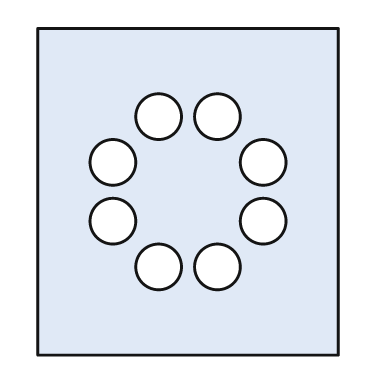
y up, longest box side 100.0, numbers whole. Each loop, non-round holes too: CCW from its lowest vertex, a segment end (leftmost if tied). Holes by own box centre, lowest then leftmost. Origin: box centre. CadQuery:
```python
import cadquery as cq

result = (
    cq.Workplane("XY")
    .moveTo(-46.0, -50.0)
    .lineTo(46.0, -50.0)
    .lineTo(46.0, 50.0)
    .lineTo(-46.0, 50.0)
    .close()
    .moveTo(-9.0, -23.0)
    .circle(7.0)
    .moveTo(9.0, -23.0)
    .circle(7.0)
    .moveTo(-23.0, -9.0)
    .circle(7.0)
    .moveTo(23.0, -9.0)
    .circle(7.0)
    .moveTo(-23.0, 9.0)
    .circle(7.0)
    .moveTo(23.0, 9.0)
    .circle(7.0)
    .moveTo(-9.0, 23.0)
    .circle(7.0)
    .moveTo(9.0, 23.0)
    .circle(7.0)
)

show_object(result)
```